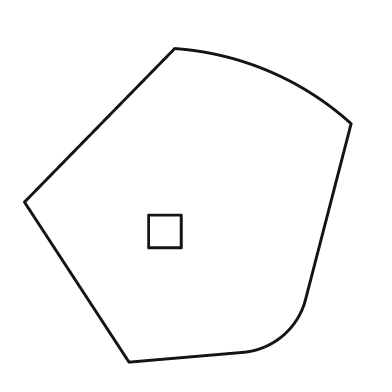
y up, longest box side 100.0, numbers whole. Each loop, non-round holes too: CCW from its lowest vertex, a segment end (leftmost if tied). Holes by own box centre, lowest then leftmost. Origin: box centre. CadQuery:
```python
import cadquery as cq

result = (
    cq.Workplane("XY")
    .moveTo(-18.0, -48.0)
    .lineTo(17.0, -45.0)
    .threePointArc((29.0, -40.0), (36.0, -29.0))
    .lineTo(50.0, 25.0)
    .threePointArc((25.0, 41.0), (-4.0, 48.0))
    .lineTo(-50.0, 1.0)
    .close()
    .moveTo(-12.0, -13.0)
    .lineTo(-2.0, -13.0)
    .lineTo(-2.0, -3.0)
    .lineTo(-12.0, -3.0)
    .close()
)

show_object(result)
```